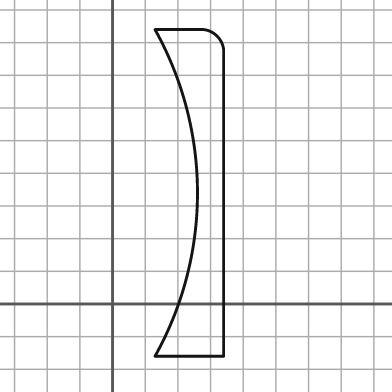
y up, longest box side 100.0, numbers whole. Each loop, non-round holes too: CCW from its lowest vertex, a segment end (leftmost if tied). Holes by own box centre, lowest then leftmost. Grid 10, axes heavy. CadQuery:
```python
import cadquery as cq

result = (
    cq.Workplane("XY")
    .moveTo(13.0, -16.0)
    .lineTo(34.0, -16.0)
    .lineTo(34.0, 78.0)
    .threePointArc((32.0, 82.0), (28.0, 84.0))
    .lineTo(13.0, 84.0)
    .threePointArc((26.0, 34.0), (13.0, -16.0))
    .close()
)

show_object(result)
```